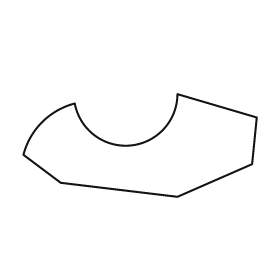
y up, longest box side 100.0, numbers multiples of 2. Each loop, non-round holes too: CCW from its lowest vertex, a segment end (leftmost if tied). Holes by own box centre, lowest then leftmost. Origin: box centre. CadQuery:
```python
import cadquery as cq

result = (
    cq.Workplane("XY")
    .moveTo(16.0, -22.0)
    .lineTo(48.0, -8.0)
    .lineTo(50.0, 12.0)
    .lineTo(16.0, 22.0)
    .threePointArc((-4.0, 0.0), (-28.0, 18.0))
    .threePointArc((-42.0, 10.0), (-50.0, -4.0))
    .lineTo(-34.0, -16.0)
    .close()
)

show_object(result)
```